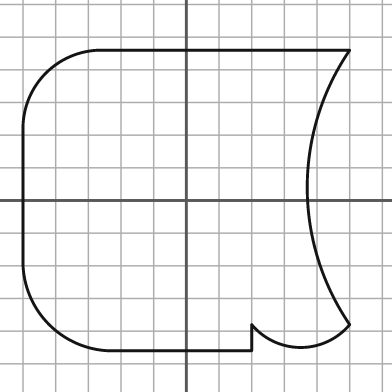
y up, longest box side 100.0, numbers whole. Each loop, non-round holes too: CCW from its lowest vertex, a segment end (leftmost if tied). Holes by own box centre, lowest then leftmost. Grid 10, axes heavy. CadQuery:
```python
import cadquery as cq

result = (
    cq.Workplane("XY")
    .moveTo(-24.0, -46.0)
    .lineTo(20.0, -46.0)
    .lineTo(20.0, -38.0)
    .threePointArc((35.0, -45.0), (50.0, -38.0))
    .threePointArc((37.0, 4.0), (50.0, 46.0))
    .lineTo(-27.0, 46.0)
    .threePointArc((-43.0, 39.0), (-50.0, 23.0))
    .lineTo(-50.0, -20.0)
    .threePointArc((-42.0, -38.0), (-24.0, -46.0))
    .close()
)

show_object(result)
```